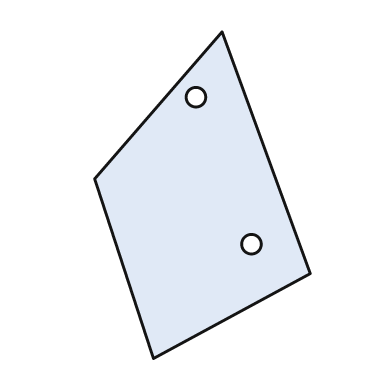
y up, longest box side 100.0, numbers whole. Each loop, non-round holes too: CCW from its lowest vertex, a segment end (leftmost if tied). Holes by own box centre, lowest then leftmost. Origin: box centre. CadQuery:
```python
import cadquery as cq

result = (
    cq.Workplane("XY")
    .moveTo(-15.0, -50.0)
    .lineTo(33.0, -24.0)
    .lineTo(6.0, 50.0)
    .lineTo(-33.0, 5.0)
    .close()
    .moveTo(15.0, -15.0)
    .circle(3.0)
    .moveTo(-2.0, 30.0)
    .circle(3.0)
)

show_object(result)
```